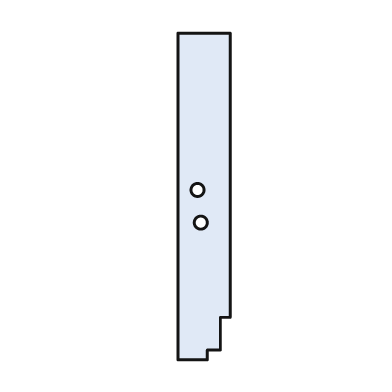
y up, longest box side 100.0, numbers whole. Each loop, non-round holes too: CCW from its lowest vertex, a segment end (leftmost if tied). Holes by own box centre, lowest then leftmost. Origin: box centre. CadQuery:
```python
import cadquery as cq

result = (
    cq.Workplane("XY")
    .moveTo(-8.0, -50.0)
    .lineTo(1.0, -50.0)
    .lineTo(1.0, -47.0)
    .lineTo(5.0, -47.0)
    .lineTo(5.0, -37.0)
    .lineTo(8.0, -37.0)
    .lineTo(8.0, 50.0)
    .lineTo(-8.0, 50.0)
    .close()
    .moveTo(-1.0, -8.0)
    .circle(2.0)
    .moveTo(-2.0, 2.0)
    .circle(2.0)
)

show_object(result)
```